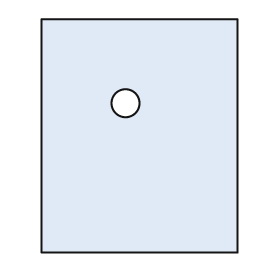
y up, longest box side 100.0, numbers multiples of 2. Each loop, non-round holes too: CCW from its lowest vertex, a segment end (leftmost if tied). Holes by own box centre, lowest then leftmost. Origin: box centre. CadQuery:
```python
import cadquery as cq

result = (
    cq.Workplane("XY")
    .moveTo(-42.0, -50.0)
    .lineTo(42.0, -50.0)
    .lineTo(42.0, 50.0)
    .lineTo(-42.0, 50.0)
    .close()
    .moveTo(-6.0, 14.0)
    .circle(6.0)
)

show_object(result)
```